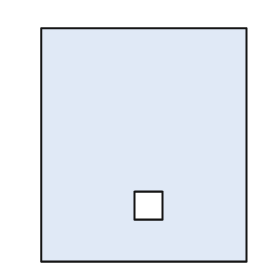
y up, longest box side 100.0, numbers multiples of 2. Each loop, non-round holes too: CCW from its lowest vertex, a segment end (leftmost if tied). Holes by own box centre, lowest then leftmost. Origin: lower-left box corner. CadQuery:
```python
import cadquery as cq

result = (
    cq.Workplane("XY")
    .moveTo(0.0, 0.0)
    .lineTo(88.0, 0.0)
    .lineTo(88.0, 100.0)
    .lineTo(0.0, 100.0)
    .close()
    .moveTo(40.0, 18.0)
    .lineTo(52.0, 18.0)
    .lineTo(52.0, 30.0)
    .lineTo(40.0, 30.0)
    .close()
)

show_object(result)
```